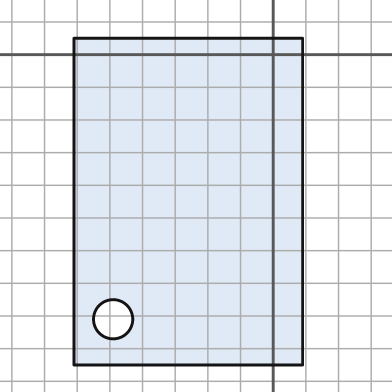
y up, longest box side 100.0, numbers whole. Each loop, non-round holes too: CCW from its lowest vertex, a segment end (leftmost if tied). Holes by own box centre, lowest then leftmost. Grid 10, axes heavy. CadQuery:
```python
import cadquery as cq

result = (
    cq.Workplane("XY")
    .moveTo(-61.0, -95.0)
    .lineTo(9.0, -95.0)
    .lineTo(9.0, 5.0)
    .lineTo(-61.0, 5.0)
    .close()
    .moveTo(-49.0, -81.0)
    .circle(6.0)
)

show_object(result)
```